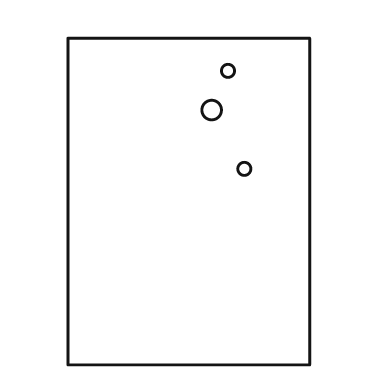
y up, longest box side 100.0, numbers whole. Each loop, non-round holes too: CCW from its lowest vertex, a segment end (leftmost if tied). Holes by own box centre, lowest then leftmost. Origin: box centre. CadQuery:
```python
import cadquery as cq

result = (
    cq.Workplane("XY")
    .moveTo(-37.0, -50.0)
    .lineTo(37.0, -50.0)
    .lineTo(37.0, 50.0)
    .lineTo(-37.0, 50.0)
    .close()
    .moveTo(17.0, 10.0)
    .circle(2.0)
    .moveTo(7.0, 28.0)
    .circle(3.0)
    .moveTo(12.0, 40.0)
    .circle(2.0)
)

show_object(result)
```